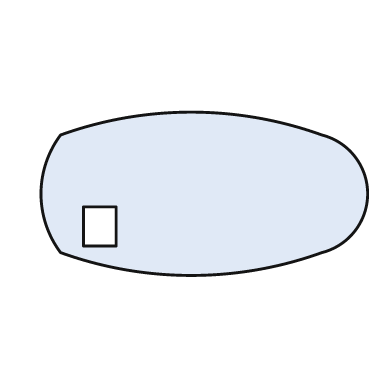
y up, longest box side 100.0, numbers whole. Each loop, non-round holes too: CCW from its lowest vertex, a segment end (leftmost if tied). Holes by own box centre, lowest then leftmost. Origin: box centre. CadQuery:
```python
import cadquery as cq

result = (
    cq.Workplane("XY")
    .moveTo(-44.0, -18.0)
    .threePointArc((-4.0, -25.0), (36.0, -18.0))
    .threePointArc((50.0, 0.0), (36.0, 18.0))
    .threePointArc((-4.0, 25.0), (-44.0, 18.0))
    .threePointArc((-50.0, 0.0), (-44.0, -18.0))
    .close()
    .moveTo(-37.0, -16.0)
    .lineTo(-27.0, -16.0)
    .lineTo(-27.0, -4.0)
    .lineTo(-37.0, -4.0)
    .close()
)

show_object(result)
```